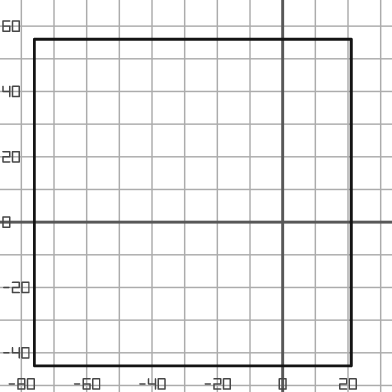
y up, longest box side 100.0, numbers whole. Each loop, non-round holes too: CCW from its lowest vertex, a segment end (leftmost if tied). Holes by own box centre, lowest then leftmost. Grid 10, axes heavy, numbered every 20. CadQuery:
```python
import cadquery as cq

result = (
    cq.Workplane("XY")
    .moveTo(-76.0, -44.0)
    .lineTo(21.0, -44.0)
    .lineTo(21.0, 56.0)
    .lineTo(-76.0, 56.0)
    .close()
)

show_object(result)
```